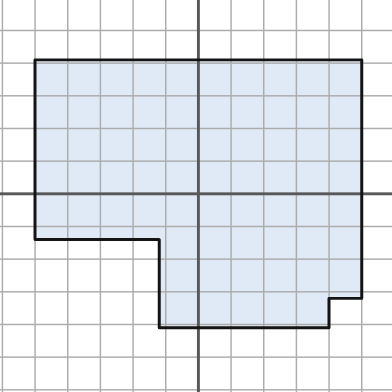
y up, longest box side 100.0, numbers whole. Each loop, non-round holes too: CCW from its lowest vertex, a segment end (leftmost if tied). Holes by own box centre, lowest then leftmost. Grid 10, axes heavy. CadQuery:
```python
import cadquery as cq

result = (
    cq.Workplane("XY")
    .moveTo(-12.0, -41.0)
    .lineTo(40.0, -41.0)
    .lineTo(40.0, -32.0)
    .lineTo(50.0, -32.0)
    .lineTo(50.0, 41.0)
    .lineTo(-50.0, 41.0)
    .lineTo(-50.0, -14.0)
    .lineTo(-12.0, -14.0)
    .close()
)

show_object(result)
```